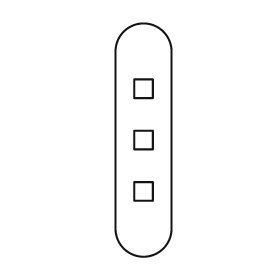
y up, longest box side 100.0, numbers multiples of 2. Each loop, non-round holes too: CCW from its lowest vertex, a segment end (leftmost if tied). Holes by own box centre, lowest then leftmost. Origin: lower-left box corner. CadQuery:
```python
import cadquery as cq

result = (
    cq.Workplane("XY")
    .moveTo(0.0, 12.0)
    .threePointArc((12.0, 0.0), (24.0, 12.0))
    .lineTo(24.0, 88.0)
    .threePointArc((12.0, 100.0), (0.0, 88.0))
    .close()
    .moveTo(8.0, 24.0)
    .lineTo(16.0, 24.0)
    .lineTo(16.0, 32.0)
    .lineTo(8.0, 32.0)
    .close()
    .moveTo(8.0, 46.0)
    .lineTo(16.0, 46.0)
    .lineTo(16.0, 54.0)
    .lineTo(8.0, 54.0)
    .close()
    .moveTo(8.0, 68.0)
    .lineTo(16.0, 68.0)
    .lineTo(16.0, 76.0)
    .lineTo(8.0, 76.0)
    .close()
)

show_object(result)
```